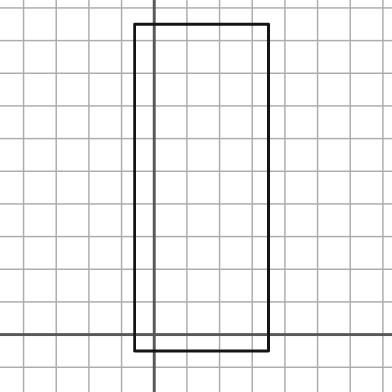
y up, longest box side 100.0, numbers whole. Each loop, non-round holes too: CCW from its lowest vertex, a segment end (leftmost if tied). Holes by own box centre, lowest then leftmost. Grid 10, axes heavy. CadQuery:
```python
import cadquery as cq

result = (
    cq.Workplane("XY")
    .moveTo(-6.0, -5.0)
    .lineTo(35.0, -5.0)
    .lineTo(35.0, 95.0)
    .lineTo(-6.0, 95.0)
    .close()
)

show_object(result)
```